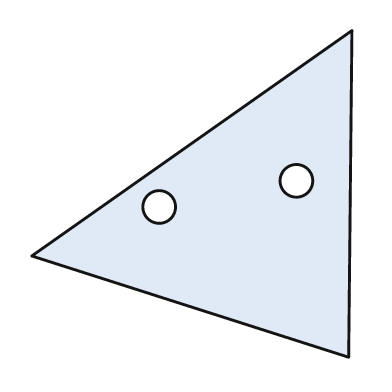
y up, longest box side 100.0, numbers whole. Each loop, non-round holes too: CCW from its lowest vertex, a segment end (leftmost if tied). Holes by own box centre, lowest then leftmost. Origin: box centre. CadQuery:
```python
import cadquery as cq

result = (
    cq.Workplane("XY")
    .moveTo(48.0, -50.0)
    .lineTo(49.0, 50.0)
    .lineTo(-49.0, -19.0)
    .close()
    .moveTo(-10.0, -4.0)
    .circle(5.0)
    .moveTo(32.0, 4.0)
    .circle(5.0)
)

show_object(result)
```